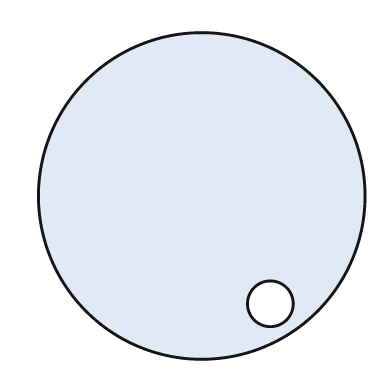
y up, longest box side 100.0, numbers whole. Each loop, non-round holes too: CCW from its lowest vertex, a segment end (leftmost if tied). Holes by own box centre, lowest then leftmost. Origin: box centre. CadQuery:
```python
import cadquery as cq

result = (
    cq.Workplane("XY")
    .moveTo(0.0, 0.0)
    .circle(50.0)
    .moveTo(21.0, -33.0)
    .circle(7.0)
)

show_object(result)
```